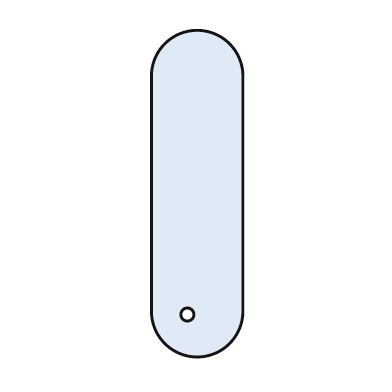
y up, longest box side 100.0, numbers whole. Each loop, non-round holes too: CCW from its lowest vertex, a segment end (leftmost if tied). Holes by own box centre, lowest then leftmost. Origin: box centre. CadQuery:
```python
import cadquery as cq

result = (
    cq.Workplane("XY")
    .moveTo(-14.0, -36.0)
    .threePointArc((0.0, -50.0), (14.0, -36.0))
    .lineTo(14.0, 36.0)
    .threePointArc((0.0, 50.0), (-14.0, 36.0))
    .close()
    .moveTo(-3.0, -37.0)
    .circle(2.0)
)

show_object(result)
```